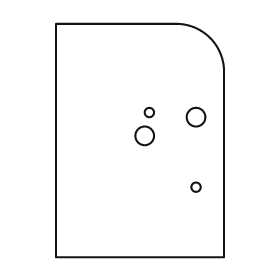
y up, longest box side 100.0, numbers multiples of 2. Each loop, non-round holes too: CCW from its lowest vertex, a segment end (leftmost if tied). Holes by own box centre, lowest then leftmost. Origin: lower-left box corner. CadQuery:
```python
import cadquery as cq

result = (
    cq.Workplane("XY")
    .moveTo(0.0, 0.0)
    .lineTo(72.0, 0.0)
    .lineTo(72.0, 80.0)
    .threePointArc((66.0, 94.0), (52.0, 100.0))
    .lineTo(0.0, 100.0)
    .close()
    .moveTo(60.0, 30.0)
    .circle(2.0)
    .moveTo(38.0, 52.0)
    .circle(4.0)
    .moveTo(60.0, 60.0)
    .circle(4.0)
    .moveTo(40.0, 62.0)
    .circle(2.0)
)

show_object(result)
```